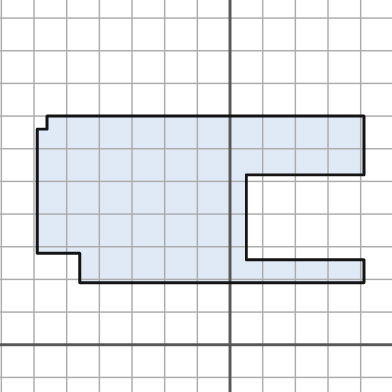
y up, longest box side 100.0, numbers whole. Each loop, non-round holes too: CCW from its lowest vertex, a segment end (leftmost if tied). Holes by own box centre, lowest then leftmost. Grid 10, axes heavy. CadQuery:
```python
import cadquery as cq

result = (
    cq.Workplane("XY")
    .moveTo(-46.0, 19.0)
    .lineTo(41.0, 19.0)
    .lineTo(41.0, 26.0)
    .lineTo(5.0, 26.0)
    .lineTo(5.0, 52.0)
    .lineTo(41.0, 52.0)
    .lineTo(41.0, 70.0)
    .lineTo(-56.0, 70.0)
    .lineTo(-56.0, 66.0)
    .lineTo(-59.0, 66.0)
    .lineTo(-59.0, 28.0)
    .lineTo(-46.0, 28.0)
    .close()
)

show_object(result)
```